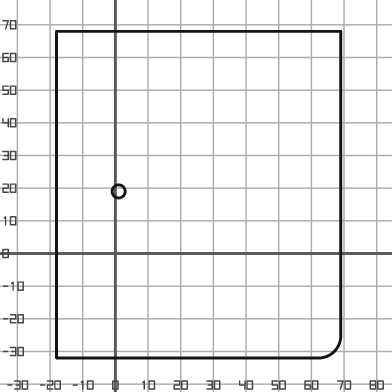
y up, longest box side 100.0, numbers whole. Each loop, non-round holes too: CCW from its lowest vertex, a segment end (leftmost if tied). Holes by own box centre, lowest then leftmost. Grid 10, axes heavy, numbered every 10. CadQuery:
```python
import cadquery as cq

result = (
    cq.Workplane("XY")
    .moveTo(-18.0, -32.0)
    .lineTo(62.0, -32.0)
    .threePointArc((67.0, -30.0), (69.0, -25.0))
    .lineTo(69.0, 68.0)
    .lineTo(-18.0, 68.0)
    .close()
    .moveTo(1.0, 19.0)
    .circle(2.0)
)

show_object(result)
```